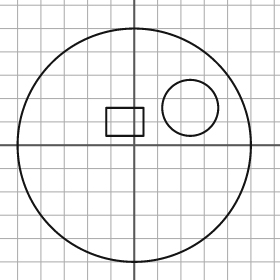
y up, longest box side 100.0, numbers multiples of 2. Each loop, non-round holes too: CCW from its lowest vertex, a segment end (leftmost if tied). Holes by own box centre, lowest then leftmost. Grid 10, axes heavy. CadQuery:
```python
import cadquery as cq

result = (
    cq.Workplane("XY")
    .moveTo(0.0, 0.0)
    .circle(50.0)
    .moveTo(-12.0, 4.0)
    .lineTo(4.0, 4.0)
    .lineTo(4.0, 16.0)
    .lineTo(-12.0, 16.0)
    .close()
    .moveTo(24.0, 16.0)
    .circle(12.0)
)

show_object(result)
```